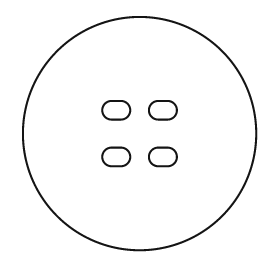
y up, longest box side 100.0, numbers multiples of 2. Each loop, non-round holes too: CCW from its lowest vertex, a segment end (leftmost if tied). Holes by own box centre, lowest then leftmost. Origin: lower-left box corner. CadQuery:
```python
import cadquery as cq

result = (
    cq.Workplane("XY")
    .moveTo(50.0, 50.0)
    .circle(50.0)
    .moveTo(38.0, 36.0)
    .lineTo(42.0, 36.0)
    .threePointArc((46.0, 40.0), (42.0, 44.0))
    .lineTo(38.0, 44.0)
    .threePointArc((34.0, 40.0), (38.0, 36.0))
    .close()
    .moveTo(58.0, 36.0)
    .lineTo(62.0, 36.0)
    .threePointArc((66.0, 40.0), (62.0, 44.0))
    .lineTo(58.0, 44.0)
    .threePointArc((54.0, 40.0), (58.0, 36.0))
    .close()
    .moveTo(38.0, 56.0)
    .lineTo(42.0, 56.0)
    .threePointArc((46.0, 60.0), (42.0, 64.0))
    .lineTo(38.0, 64.0)
    .threePointArc((34.0, 60.0), (38.0, 56.0))
    .close()
    .moveTo(58.0, 56.0)
    .lineTo(62.0, 56.0)
    .threePointArc((66.0, 60.0), (62.0, 64.0))
    .lineTo(58.0, 64.0)
    .threePointArc((54.0, 60.0), (58.0, 56.0))
    .close()
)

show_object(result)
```